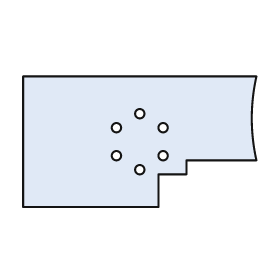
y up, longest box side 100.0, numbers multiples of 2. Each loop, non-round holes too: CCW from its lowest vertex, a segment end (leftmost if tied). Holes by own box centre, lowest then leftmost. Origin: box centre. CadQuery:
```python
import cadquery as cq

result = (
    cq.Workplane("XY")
    .moveTo(-50.0, -28.0)
    .lineTo(8.0, -28.0)
    .lineTo(8.0, -14.0)
    .lineTo(20.0, -14.0)
    .lineTo(20.0, -8.0)
    .lineTo(50.0, -8.0)
    .threePointArc((48.0, 10.0), (50.0, 28.0))
    .lineTo(-50.0, 28.0)
    .close()
    .moveTo(0.0, -12.0)
    .circle(2.0)
    .moveTo(-10.0, -6.0)
    .circle(2.0)
    .moveTo(10.0, -6.0)
    .circle(2.0)
    .moveTo(-10.0, 6.0)
    .circle(2.0)
    .moveTo(10.0, 6.0)
    .circle(2.0)
    .moveTo(0.0, 12.0)
    .circle(2.0)
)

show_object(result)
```